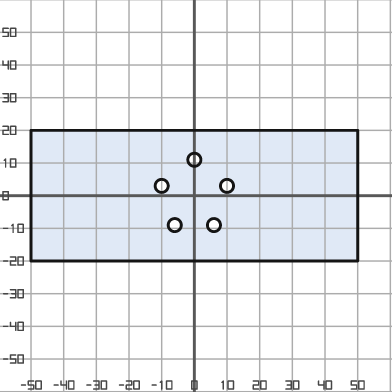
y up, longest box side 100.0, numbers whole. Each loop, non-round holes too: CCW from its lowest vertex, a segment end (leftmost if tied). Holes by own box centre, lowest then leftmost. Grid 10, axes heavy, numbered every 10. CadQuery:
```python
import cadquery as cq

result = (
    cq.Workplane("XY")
    .moveTo(-50.0, -20.0)
    .lineTo(50.0, -20.0)
    .lineTo(50.0, 20.0)
    .lineTo(-50.0, 20.0)
    .close()
    .moveTo(-6.0, -9.0)
    .circle(2.0)
    .moveTo(6.0, -9.0)
    .circle(2.0)
    .moveTo(-10.0, 3.0)
    .circle(2.0)
    .moveTo(10.0, 3.0)
    .circle(2.0)
    .moveTo(0.0, 11.0)
    .circle(2.0)
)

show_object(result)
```